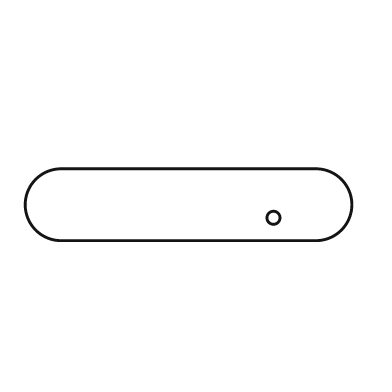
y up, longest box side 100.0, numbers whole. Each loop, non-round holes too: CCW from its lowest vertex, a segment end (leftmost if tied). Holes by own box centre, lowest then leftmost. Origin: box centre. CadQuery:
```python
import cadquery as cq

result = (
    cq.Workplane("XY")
    .moveTo(-39.0, -11.0)
    .lineTo(39.0, -11.0)
    .threePointArc((50.0, 0.0), (39.0, 11.0))
    .lineTo(-39.0, 11.0)
    .threePointArc((-50.0, 0.0), (-39.0, -11.0))
    .close()
    .moveTo(26.0, -4.0)
    .circle(2.0)
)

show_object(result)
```